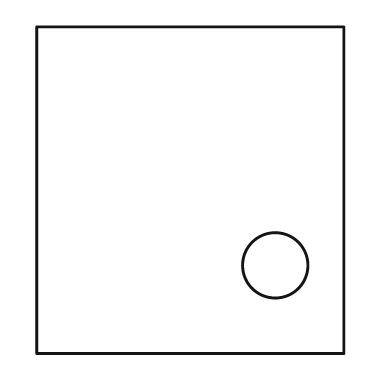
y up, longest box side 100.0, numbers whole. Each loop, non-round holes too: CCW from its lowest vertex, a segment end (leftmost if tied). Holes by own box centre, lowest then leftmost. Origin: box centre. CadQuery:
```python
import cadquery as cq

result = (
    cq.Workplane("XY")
    .moveTo(-47.0, -50.0)
    .lineTo(47.0, -50.0)
    .lineTo(47.0, 50.0)
    .lineTo(-47.0, 50.0)
    .close()
    .moveTo(26.0, -23.0)
    .circle(10.0)
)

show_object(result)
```